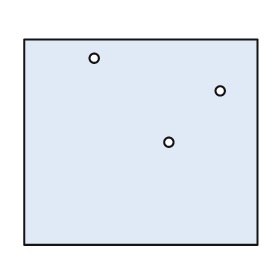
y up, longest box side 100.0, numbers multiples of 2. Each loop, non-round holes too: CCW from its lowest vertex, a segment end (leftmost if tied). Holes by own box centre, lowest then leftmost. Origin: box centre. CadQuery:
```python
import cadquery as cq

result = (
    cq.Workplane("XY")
    .moveTo(-50.0, -44.0)
    .lineTo(50.0, -44.0)
    .lineTo(50.0, 44.0)
    .lineTo(-50.0, 44.0)
    .close()
    .moveTo(12.0, 0.0)
    .circle(2.0)
    .moveTo(34.0, 22.0)
    .circle(2.0)
    .moveTo(-20.0, 36.0)
    .circle(2.0)
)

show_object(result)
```